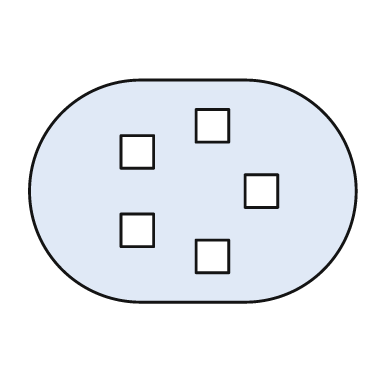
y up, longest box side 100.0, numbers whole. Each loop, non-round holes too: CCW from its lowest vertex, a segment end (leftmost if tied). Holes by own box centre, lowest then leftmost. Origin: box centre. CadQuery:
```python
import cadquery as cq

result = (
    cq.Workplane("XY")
    .moveTo(-16.0, -34.0)
    .lineTo(16.0, -34.0)
    .threePointArc((50.0, 0.0), (16.0, 34.0))
    .lineTo(-16.0, 34.0)
    .threePointArc((-50.0, 0.0), (-16.0, -34.0))
    .close()
    .moveTo(1.0, -25.0)
    .lineTo(11.0, -25.0)
    .lineTo(11.0, -15.0)
    .lineTo(1.0, -15.0)
    .close()
    .moveTo(-22.0, -17.0)
    .lineTo(-12.0, -17.0)
    .lineTo(-12.0, -7.0)
    .lineTo(-22.0, -7.0)
    .close()
    .moveTo(16.0, -5.0)
    .lineTo(26.0, -5.0)
    .lineTo(26.0, 5.0)
    .lineTo(16.0, 5.0)
    .close()
    .moveTo(-22.0, 7.0)
    .lineTo(-12.0, 7.0)
    .lineTo(-12.0, 17.0)
    .lineTo(-22.0, 17.0)
    .close()
    .moveTo(1.0, 15.0)
    .lineTo(11.0, 15.0)
    .lineTo(11.0, 25.0)
    .lineTo(1.0, 25.0)
    .close()
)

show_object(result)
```